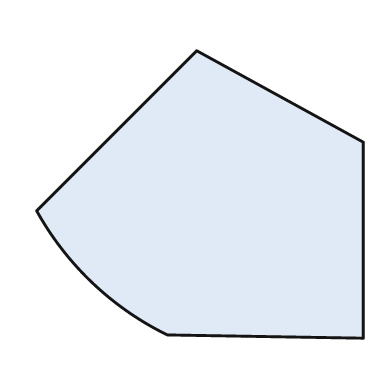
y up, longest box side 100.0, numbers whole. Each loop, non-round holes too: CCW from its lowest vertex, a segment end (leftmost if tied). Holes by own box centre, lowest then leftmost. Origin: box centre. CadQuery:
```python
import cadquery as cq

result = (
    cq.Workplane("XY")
    .moveTo(50.0, -44.0)
    .lineTo(50.0, 16.0)
    .lineTo(-1.0, 44.0)
    .lineTo(-50.0, -5.0)
    .threePointArc((-33.0, -27.0), (-10.0, -43.0))
    .close()
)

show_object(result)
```